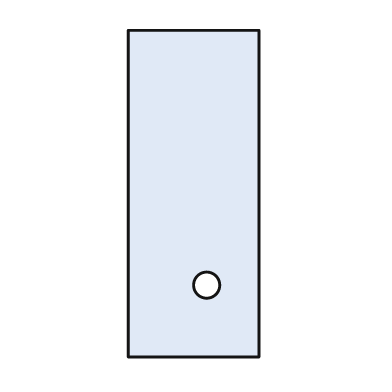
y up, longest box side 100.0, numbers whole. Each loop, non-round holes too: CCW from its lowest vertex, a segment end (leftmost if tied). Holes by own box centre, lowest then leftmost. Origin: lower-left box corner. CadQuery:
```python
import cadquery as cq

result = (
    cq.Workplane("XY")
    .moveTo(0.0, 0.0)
    .lineTo(40.0, 0.0)
    .lineTo(40.0, 100.0)
    .lineTo(0.0, 100.0)
    .close()
    .moveTo(24.0, 22.0)
    .circle(4.0)
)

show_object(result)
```